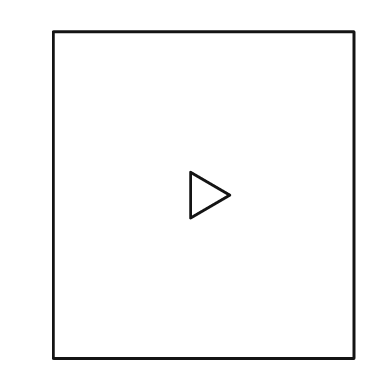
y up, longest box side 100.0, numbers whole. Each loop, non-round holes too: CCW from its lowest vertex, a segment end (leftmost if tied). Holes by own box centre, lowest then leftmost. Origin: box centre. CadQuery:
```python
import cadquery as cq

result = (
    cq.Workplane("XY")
    .moveTo(-46.0, -50.0)
    .lineTo(46.0, -50.0)
    .lineTo(46.0, 50.0)
    .lineTo(-46.0, 50.0)
    .close()
    .moveTo(-4.0, -7.0)
    .lineTo(8.0, 0.0)
    .lineTo(-4.0, 7.0)
    .close()
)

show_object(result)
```